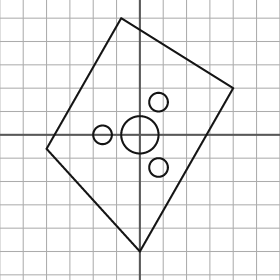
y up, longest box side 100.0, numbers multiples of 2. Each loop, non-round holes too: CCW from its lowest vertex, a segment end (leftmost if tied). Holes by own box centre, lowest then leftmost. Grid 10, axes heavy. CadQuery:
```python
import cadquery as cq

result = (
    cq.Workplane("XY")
    .moveTo(0.0, -50.0)
    .lineTo(40.0, 20.0)
    .lineTo(-8.0, 50.0)
    .lineTo(-40.0, -6.0)
    .close()
    .moveTo(8.0, -14.0)
    .circle(4.0)
    .moveTo(-16.0, 0.0)
    .circle(4.0)
    .moveTo(0.0, 0.0)
    .circle(8.0)
    .moveTo(8.0, 14.0)
    .circle(4.0)
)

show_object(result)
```